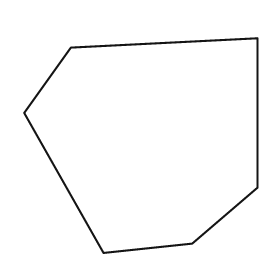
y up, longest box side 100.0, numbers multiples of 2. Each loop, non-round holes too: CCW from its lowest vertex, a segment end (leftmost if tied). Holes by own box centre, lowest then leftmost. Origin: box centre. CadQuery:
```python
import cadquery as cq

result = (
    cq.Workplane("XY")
    .moveTo(-16.0, -46.0)
    .lineTo(22.0, -42.0)
    .lineTo(50.0, -18.0)
    .lineTo(50.0, 46.0)
    .lineTo(-30.0, 42.0)
    .lineTo(-50.0, 14.0)
    .close()
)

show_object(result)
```